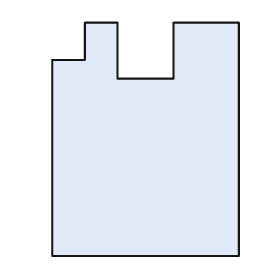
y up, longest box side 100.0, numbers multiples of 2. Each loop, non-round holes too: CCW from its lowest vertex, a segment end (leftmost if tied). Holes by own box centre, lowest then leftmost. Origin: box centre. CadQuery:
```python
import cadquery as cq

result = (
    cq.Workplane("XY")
    .moveTo(-40.0, -50.0)
    .lineTo(40.0, -50.0)
    .lineTo(40.0, 50.0)
    .lineTo(12.0, 50.0)
    .lineTo(12.0, 26.0)
    .lineTo(-12.0, 26.0)
    .lineTo(-12.0, 50.0)
    .lineTo(-26.0, 50.0)
    .lineTo(-26.0, 34.0)
    .lineTo(-40.0, 34.0)
    .close()
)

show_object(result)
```